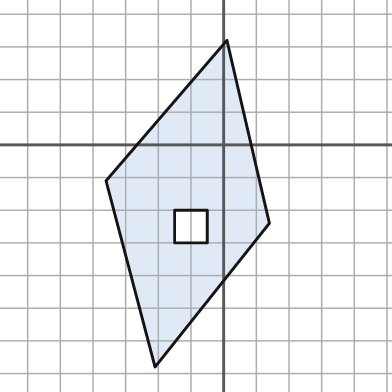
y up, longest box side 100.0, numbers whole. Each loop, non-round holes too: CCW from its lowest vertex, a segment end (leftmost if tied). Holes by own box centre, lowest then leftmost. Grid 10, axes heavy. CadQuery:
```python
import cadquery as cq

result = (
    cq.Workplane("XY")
    .moveTo(-21.0, -68.0)
    .lineTo(14.0, -24.0)
    .lineTo(1.0, 32.0)
    .lineTo(-36.0, -11.0)
    .close()
    .moveTo(-15.0, -30.0)
    .lineTo(-5.0, -30.0)
    .lineTo(-5.0, -20.0)
    .lineTo(-15.0, -20.0)
    .close()
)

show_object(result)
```